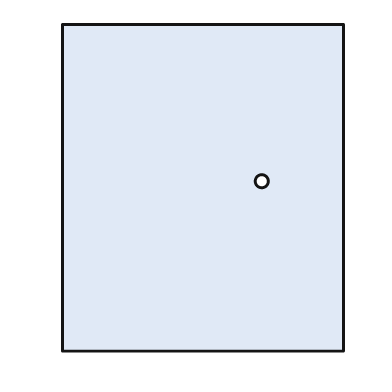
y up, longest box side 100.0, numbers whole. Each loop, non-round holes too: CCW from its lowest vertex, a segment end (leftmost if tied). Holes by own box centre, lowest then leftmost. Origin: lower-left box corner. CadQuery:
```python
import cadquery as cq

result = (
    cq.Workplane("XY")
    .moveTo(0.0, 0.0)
    .lineTo(86.0, 0.0)
    .lineTo(86.0, 100.0)
    .lineTo(0.0, 100.0)
    .close()
    .moveTo(61.0, 52.0)
    .circle(2.0)
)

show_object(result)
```